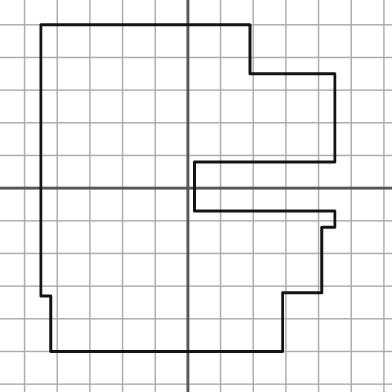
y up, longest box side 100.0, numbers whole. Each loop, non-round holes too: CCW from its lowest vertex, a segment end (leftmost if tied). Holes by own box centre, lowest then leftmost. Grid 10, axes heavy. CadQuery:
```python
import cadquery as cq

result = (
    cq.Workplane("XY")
    .moveTo(-42.0, -50.0)
    .lineTo(29.0, -50.0)
    .lineTo(29.0, -32.0)
    .lineTo(41.0, -32.0)
    .lineTo(41.0, -12.0)
    .lineTo(45.0, -12.0)
    .lineTo(45.0, -7.0)
    .lineTo(2.0, -7.0)
    .lineTo(2.0, 8.0)
    .lineTo(45.0, 8.0)
    .lineTo(45.0, 35.0)
    .lineTo(19.0, 35.0)
    .lineTo(19.0, 50.0)
    .lineTo(-45.0, 50.0)
    .lineTo(-45.0, -33.0)
    .lineTo(-42.0, -33.0)
    .close()
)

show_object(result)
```